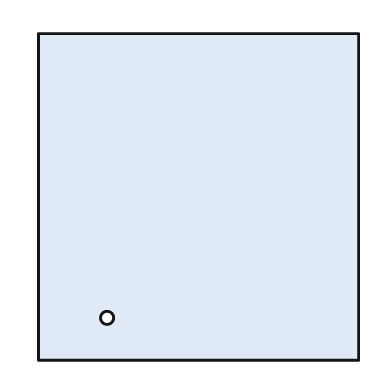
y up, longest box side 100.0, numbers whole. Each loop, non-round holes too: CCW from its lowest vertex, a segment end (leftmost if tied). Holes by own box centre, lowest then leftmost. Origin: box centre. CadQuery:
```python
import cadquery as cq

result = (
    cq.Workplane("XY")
    .moveTo(-49.0, -50.0)
    .lineTo(49.0, -50.0)
    .lineTo(49.0, 50.0)
    .lineTo(-49.0, 50.0)
    .close()
    .moveTo(-28.0, -37.0)
    .circle(2.0)
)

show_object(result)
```